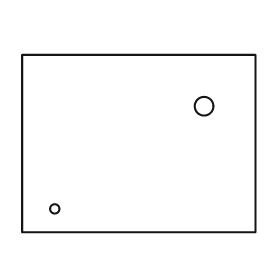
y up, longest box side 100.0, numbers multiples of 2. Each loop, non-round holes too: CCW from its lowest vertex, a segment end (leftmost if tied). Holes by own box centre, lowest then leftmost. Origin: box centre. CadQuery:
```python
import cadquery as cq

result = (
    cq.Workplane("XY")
    .moveTo(-50.0, -38.0)
    .lineTo(50.0, -38.0)
    .lineTo(50.0, 38.0)
    .lineTo(-50.0, 38.0)
    .close()
    .moveTo(-36.0, -28.0)
    .circle(2.0)
    .moveTo(28.0, 16.0)
    .circle(4.0)
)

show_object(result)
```